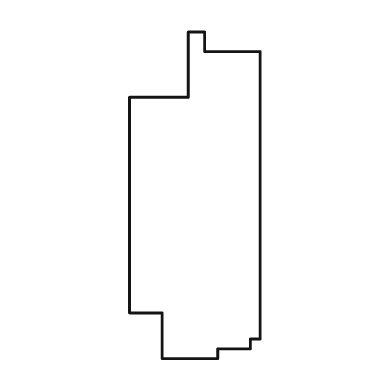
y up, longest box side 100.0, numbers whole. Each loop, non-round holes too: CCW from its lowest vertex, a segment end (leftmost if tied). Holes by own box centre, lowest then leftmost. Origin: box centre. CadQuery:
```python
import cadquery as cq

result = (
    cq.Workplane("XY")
    .moveTo(-10.0, -50.0)
    .lineTo(7.0, -50.0)
    .lineTo(7.0, -47.0)
    .lineTo(17.0, -47.0)
    .lineTo(17.0, -44.0)
    .lineTo(20.0, -44.0)
    .lineTo(20.0, 44.0)
    .lineTo(3.0, 44.0)
    .lineTo(3.0, 50.0)
    .lineTo(-2.0, 50.0)
    .lineTo(-2.0, 30.0)
    .lineTo(-20.0, 30.0)
    .lineTo(-20.0, -36.0)
    .lineTo(-10.0, -36.0)
    .close()
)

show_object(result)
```